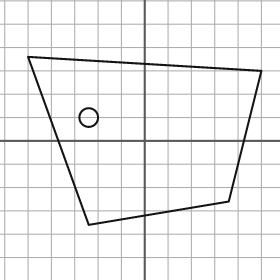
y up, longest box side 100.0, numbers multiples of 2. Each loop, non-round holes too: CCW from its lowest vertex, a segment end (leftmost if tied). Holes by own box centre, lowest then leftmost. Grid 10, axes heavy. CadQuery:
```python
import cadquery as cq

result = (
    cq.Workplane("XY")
    .moveTo(-24.0, -36.0)
    .lineTo(36.0, -26.0)
    .lineTo(50.0, 30.0)
    .lineTo(-50.0, 36.0)
    .close()
    .moveTo(-24.0, 10.0)
    .circle(4.0)
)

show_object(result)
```